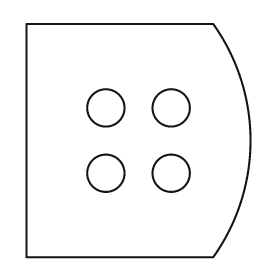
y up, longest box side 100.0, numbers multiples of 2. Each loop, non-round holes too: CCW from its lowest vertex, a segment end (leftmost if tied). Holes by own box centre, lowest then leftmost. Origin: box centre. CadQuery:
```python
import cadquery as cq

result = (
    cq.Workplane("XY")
    .moveTo(-48.0, -50.0)
    .lineTo(32.0, -50.0)
    .threePointArc((48.0, 0.0), (32.0, 50.0))
    .lineTo(-48.0, 50.0)
    .close()
    .moveTo(-14.0, -14.0)
    .circle(8.0)
    .moveTo(14.0, -14.0)
    .circle(8.0)
    .moveTo(-14.0, 14.0)
    .circle(8.0)
    .moveTo(14.0, 14.0)
    .circle(8.0)
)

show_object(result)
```